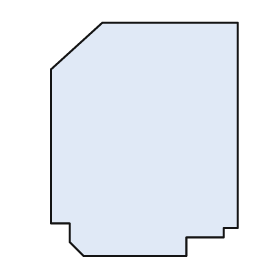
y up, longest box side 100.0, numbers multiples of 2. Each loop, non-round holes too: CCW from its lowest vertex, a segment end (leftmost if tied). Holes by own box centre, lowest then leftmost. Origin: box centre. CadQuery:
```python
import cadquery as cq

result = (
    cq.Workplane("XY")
    .moveTo(-26.0, -50.0)
    .lineTo(18.0, -50.0)
    .lineTo(18.0, -42.0)
    .lineTo(34.0, -42.0)
    .lineTo(34.0, -38.0)
    .lineTo(40.0, -38.0)
    .lineTo(40.0, 50.0)
    .lineTo(-18.0, 50.0)
    .lineTo(-40.0, 30.0)
    .lineTo(-40.0, -36.0)
    .lineTo(-32.0, -36.0)
    .lineTo(-32.0, -44.0)
    .close()
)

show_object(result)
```